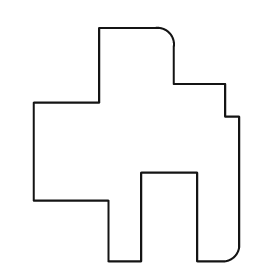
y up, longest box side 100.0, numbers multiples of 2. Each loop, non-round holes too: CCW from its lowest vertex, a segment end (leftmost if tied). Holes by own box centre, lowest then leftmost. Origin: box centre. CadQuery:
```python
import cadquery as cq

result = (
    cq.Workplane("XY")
    .moveTo(-12.0, -50.0)
    .lineTo(2.0, -50.0)
    .lineTo(2.0, -12.0)
    .lineTo(26.0, -12.0)
    .lineTo(26.0, -50.0)
    .lineTo(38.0, -50.0)
    .threePointArc((42.0, -48.0), (44.0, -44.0))
    .lineTo(44.0, 12.0)
    .lineTo(38.0, 12.0)
    .lineTo(38.0, 26.0)
    .lineTo(16.0, 26.0)
    .lineTo(16.0, 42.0)
    .threePointArc((14.0, 48.0), (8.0, 50.0))
    .lineTo(-16.0, 50.0)
    .lineTo(-16.0, 18.0)
    .lineTo(-44.0, 18.0)
    .lineTo(-44.0, -24.0)
    .lineTo(-12.0, -24.0)
    .close()
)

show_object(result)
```